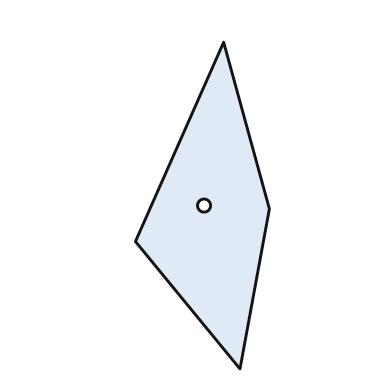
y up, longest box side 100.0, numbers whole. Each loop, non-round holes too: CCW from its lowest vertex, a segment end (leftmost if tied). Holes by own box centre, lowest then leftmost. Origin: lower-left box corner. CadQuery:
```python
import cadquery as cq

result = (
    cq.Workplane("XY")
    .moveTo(32.0, 0.0)
    .lineTo(41.0, 49.0)
    .lineTo(27.0, 100.0)
    .lineTo(0.0, 39.0)
    .close()
    .moveTo(21.0, 50.0)
    .circle(2.0)
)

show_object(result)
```